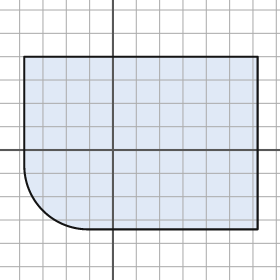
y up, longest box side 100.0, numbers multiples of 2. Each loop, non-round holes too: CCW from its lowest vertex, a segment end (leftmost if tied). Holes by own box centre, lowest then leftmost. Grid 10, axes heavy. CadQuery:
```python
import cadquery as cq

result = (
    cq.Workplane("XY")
    .moveTo(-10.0, -34.0)
    .lineTo(62.0, -34.0)
    .lineTo(62.0, 40.0)
    .lineTo(-38.0, 40.0)
    .lineTo(-38.0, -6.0)
    .threePointArc((-30.0, -26.0), (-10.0, -34.0))
    .close()
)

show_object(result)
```